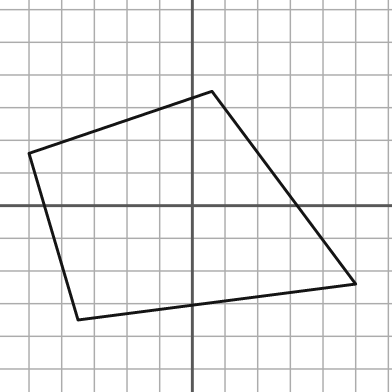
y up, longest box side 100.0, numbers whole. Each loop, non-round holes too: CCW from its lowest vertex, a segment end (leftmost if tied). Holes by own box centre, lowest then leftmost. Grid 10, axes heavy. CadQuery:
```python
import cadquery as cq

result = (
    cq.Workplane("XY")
    .moveTo(-35.0, -35.0)
    .lineTo(50.0, -24.0)
    .lineTo(6.0, 35.0)
    .lineTo(-50.0, 16.0)
    .close()
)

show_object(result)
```